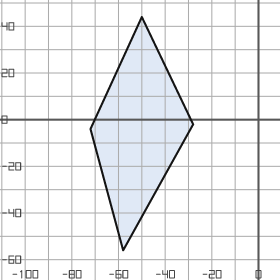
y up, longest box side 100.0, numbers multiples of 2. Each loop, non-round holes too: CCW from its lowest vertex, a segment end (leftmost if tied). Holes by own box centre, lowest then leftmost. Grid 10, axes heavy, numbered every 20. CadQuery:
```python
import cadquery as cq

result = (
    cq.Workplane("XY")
    .moveTo(-58.0, -56.0)
    .lineTo(-28.0, -2.0)
    .lineTo(-50.0, 44.0)
    .lineTo(-72.0, -4.0)
    .close()
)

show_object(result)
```